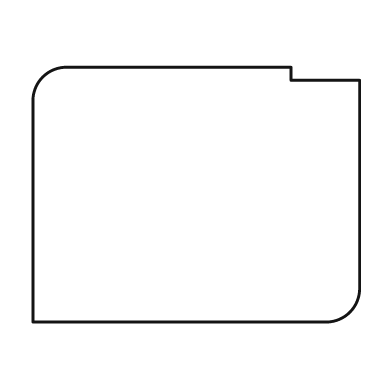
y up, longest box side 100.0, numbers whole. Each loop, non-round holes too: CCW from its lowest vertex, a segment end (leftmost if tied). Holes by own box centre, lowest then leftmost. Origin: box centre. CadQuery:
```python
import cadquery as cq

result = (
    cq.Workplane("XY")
    .moveTo(-50.0, -39.0)
    .lineTo(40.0, -39.0)
    .threePointArc((47.0, -36.0), (50.0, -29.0))
    .lineTo(50.0, 35.0)
    .lineTo(29.0, 35.0)
    .lineTo(29.0, 39.0)
    .lineTo(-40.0, 39.0)
    .threePointArc((-47.0, 36.0), (-50.0, 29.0))
    .close()
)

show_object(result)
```